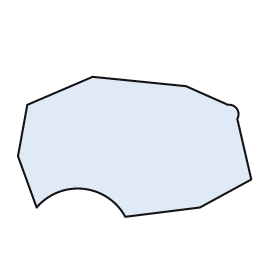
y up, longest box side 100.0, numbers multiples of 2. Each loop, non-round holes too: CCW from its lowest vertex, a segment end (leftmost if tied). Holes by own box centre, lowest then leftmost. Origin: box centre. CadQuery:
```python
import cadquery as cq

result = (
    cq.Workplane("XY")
    .moveTo(-4.0, -30.0)
    .lineTo(28.0, -26.0)
    .lineTo(50.0, -14.0)
    .lineTo(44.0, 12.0)
    .threePointArc((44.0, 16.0), (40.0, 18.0))
    .lineTo(22.0, 26.0)
    .lineTo(-18.0, 30.0)
    .lineTo(-46.0, 18.0)
    .lineTo(-50.0, -4.0)
    .lineTo(-42.0, -26.0)
    .threePointArc((-22.0, -18.0), (-4.0, -30.0))
    .close()
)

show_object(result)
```